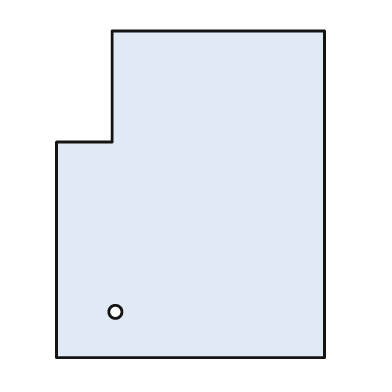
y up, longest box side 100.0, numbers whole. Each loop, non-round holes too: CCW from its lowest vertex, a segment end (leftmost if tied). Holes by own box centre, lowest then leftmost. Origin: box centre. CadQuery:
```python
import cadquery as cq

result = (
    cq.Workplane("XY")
    .moveTo(-41.0, -50.0)
    .lineTo(41.0, -50.0)
    .lineTo(41.0, 50.0)
    .lineTo(-24.0, 50.0)
    .lineTo(-24.0, 16.0)
    .lineTo(-41.0, 16.0)
    .close()
    .moveTo(-23.0, -36.0)
    .circle(2.0)
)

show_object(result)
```